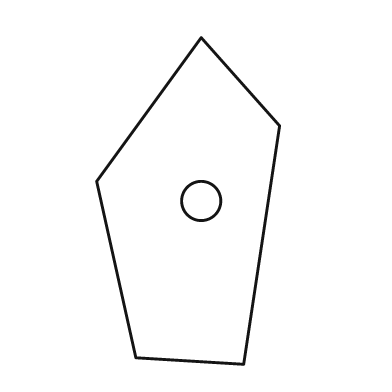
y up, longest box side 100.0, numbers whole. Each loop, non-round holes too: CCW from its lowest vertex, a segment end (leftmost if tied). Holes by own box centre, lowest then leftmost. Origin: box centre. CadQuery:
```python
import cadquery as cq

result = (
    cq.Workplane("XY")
    .moveTo(17.0, -50.0)
    .lineTo(28.0, 23.0)
    .lineTo(4.0, 50.0)
    .lineTo(-28.0, 6.0)
    .lineTo(-16.0, -48.0)
    .close()
    .moveTo(4.0, 0.0)
    .circle(6.0)
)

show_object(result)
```